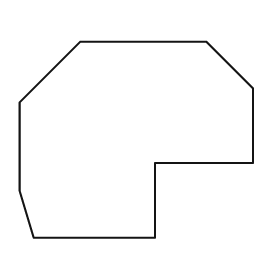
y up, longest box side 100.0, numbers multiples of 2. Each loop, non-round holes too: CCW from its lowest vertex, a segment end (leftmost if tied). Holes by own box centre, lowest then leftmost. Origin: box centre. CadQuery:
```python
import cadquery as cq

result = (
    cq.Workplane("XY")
    .moveTo(-44.0, -42.0)
    .lineTo(8.0, -42.0)
    .lineTo(8.0, -10.0)
    .lineTo(50.0, -10.0)
    .lineTo(50.0, 22.0)
    .lineTo(30.0, 42.0)
    .lineTo(-24.0, 42.0)
    .lineTo(-50.0, 16.0)
    .lineTo(-50.0, -22.0)
    .close()
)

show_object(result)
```